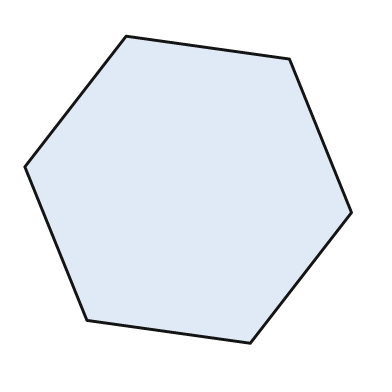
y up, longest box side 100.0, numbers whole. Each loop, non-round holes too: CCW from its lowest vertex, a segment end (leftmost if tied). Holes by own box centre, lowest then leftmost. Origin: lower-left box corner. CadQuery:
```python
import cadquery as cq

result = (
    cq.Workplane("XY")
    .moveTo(69.0, 0.0)
    .lineTo(100.0, 40.0)
    .lineTo(81.0, 87.0)
    .lineTo(31.0, 94.0)
    .lineTo(0.0, 54.0)
    .lineTo(19.0, 7.0)
    .close()
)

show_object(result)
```